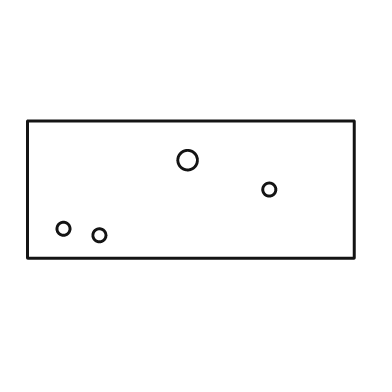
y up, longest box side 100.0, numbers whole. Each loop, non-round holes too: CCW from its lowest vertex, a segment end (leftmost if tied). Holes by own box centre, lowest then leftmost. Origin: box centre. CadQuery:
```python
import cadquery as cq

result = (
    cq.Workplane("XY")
    .moveTo(-50.0, -21.0)
    .lineTo(50.0, -21.0)
    .lineTo(50.0, 21.0)
    .lineTo(-50.0, 21.0)
    .close()
    .moveTo(-28.0, -14.0)
    .circle(2.0)
    .moveTo(-39.0, -12.0)
    .circle(2.0)
    .moveTo(24.0, 0.0)
    .circle(2.0)
    .moveTo(-1.0, 9.0)
    .circle(3.0)
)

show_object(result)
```